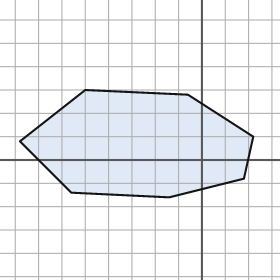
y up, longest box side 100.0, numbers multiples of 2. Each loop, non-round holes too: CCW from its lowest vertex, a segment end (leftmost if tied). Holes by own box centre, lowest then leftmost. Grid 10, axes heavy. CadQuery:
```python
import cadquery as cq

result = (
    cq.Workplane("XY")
    .moveTo(-14.0, -16.0)
    .lineTo(18.0, -8.0)
    .lineTo(22.0, 10.0)
    .lineTo(-6.0, 28.0)
    .lineTo(-50.0, 30.0)
    .lineTo(-78.0, 8.0)
    .lineTo(-56.0, -14.0)
    .close()
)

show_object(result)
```